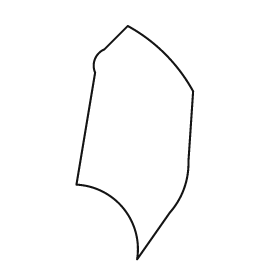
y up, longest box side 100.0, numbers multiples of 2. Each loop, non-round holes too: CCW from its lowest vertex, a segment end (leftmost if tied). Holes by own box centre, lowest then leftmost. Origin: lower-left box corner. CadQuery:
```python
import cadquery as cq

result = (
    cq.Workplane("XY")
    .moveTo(26.0, 0.0)
    .lineTo(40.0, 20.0)
    .threePointArc((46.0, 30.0), (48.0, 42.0))
    .lineTo(50.0, 72.0)
    .threePointArc((38.0, 88.0), (22.0, 100.0))
    .lineTo(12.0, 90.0)
    .threePointArc((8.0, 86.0), (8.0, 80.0))
    .lineTo(0.0, 32.0)
    .threePointArc((20.0, 22.0), (26.0, 0.0))
    .close()
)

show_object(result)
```